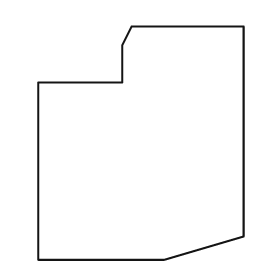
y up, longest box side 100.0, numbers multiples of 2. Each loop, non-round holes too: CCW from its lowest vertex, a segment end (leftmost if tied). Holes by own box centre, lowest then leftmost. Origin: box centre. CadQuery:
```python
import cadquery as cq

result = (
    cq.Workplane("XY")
    .moveTo(-44.0, -50.0)
    .lineTo(10.0, -50.0)
    .lineTo(44.0, -40.0)
    .lineTo(44.0, 50.0)
    .lineTo(-4.0, 50.0)
    .lineTo(-8.0, 42.0)
    .lineTo(-8.0, 26.0)
    .lineTo(-44.0, 26.0)
    .close()
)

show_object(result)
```